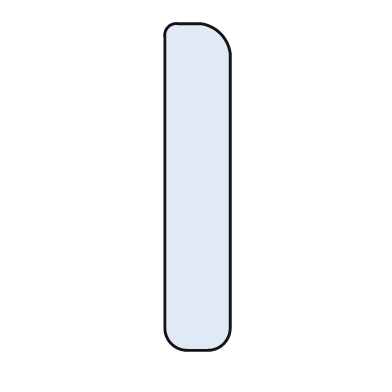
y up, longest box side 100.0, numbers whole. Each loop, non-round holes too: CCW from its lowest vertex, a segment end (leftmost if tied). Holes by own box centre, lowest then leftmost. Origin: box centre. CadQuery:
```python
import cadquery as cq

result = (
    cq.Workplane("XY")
    .moveTo(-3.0, -50.0)
    .lineTo(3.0, -50.0)
    .threePointArc((8.0, -48.0), (10.0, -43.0))
    .lineTo(10.0, 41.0)
    .threePointArc((7.0, 47.0), (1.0, 50.0))
    .lineTo(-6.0, 50.0)
    .threePointArc((-9.0, 49.0), (-10.0, 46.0))
    .lineTo(-10.0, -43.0)
    .threePointArc((-8.0, -48.0), (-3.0, -50.0))
    .close()
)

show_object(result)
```